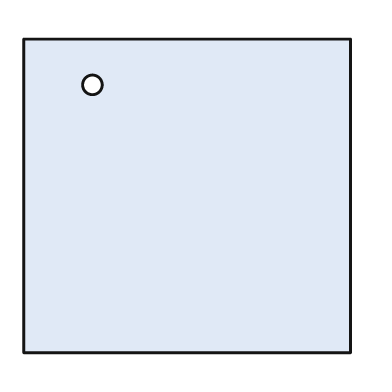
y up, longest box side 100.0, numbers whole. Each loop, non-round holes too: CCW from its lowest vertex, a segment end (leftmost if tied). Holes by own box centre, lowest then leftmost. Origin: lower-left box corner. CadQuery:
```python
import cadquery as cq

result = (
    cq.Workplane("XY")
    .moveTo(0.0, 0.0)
    .lineTo(100.0, 0.0)
    .lineTo(100.0, 96.0)
    .lineTo(0.0, 96.0)
    .close()
    .moveTo(21.0, 82.0)
    .circle(3.0)
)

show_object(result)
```